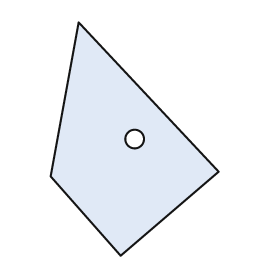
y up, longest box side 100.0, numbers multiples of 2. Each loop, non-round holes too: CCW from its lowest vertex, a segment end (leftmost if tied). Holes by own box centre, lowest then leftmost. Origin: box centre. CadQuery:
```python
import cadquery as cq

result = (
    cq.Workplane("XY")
    .moveTo(-6.0, -50.0)
    .lineTo(36.0, -14.0)
    .lineTo(-24.0, 50.0)
    .lineTo(-36.0, -16.0)
    .close()
    .moveTo(0.0, 0.0)
    .circle(4.0)
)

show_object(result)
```